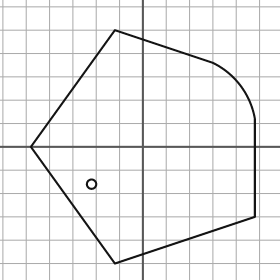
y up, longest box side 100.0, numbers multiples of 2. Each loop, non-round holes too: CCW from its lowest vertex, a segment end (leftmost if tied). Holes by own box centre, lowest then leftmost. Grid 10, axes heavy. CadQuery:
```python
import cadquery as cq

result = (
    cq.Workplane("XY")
    .moveTo(-12.0, -50.0)
    .lineTo(48.0, -30.0)
    .lineTo(48.0, 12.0)
    .threePointArc((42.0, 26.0), (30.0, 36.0))
    .lineTo(-12.0, 50.0)
    .lineTo(-48.0, 0.0)
    .close()
    .moveTo(-22.0, -16.0)
    .circle(2.0)
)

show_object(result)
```